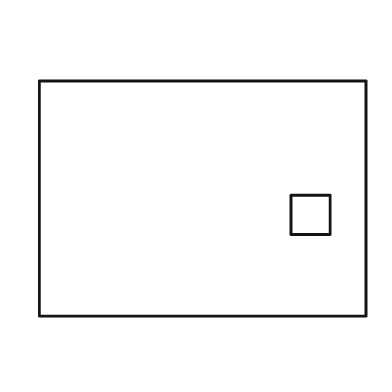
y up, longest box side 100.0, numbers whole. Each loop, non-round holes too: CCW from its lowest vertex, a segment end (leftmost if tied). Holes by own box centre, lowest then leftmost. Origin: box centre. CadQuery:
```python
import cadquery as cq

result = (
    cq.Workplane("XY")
    .moveTo(-50.0, -36.0)
    .lineTo(50.0, -36.0)
    .lineTo(50.0, 36.0)
    .lineTo(-50.0, 36.0)
    .close()
    .moveTo(27.0, -11.0)
    .lineTo(39.0, -11.0)
    .lineTo(39.0, 1.0)
    .lineTo(27.0, 1.0)
    .close()
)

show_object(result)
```